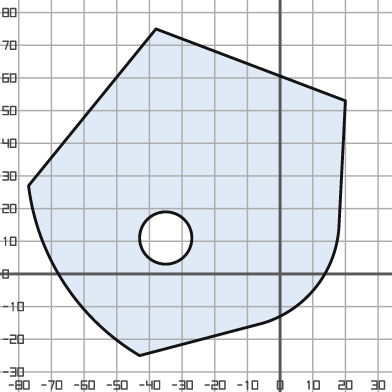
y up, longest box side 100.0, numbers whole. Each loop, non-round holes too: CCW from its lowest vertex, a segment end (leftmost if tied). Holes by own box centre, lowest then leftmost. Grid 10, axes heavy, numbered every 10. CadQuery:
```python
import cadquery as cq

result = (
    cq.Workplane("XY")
    .moveTo(-43.0, -25.0)
    .lineTo(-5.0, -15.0)
    .threePointArc((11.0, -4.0), (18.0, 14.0))
    .lineTo(20.0, 53.0)
    .lineTo(-38.0, 75.0)
    .lineTo(-77.0, 27.0)
    .threePointArc((-66.0, -3.0), (-43.0, -25.0))
    .close()
    .moveTo(-35.0, 11.0)
    .circle(8.0)
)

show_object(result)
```